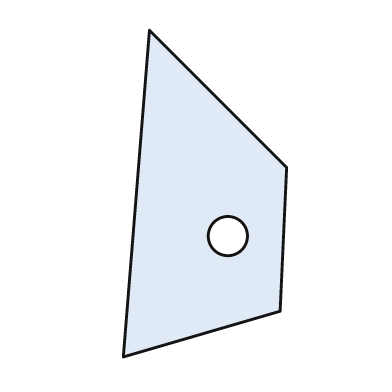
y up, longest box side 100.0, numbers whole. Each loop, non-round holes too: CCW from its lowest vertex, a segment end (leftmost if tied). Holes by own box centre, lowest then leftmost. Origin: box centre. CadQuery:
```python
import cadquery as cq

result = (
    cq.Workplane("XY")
    .moveTo(-25.0, -50.0)
    .lineTo(23.0, -36.0)
    .lineTo(25.0, 8.0)
    .lineTo(-17.0, 50.0)
    .close()
    .moveTo(7.0, -13.0)
    .circle(6.0)
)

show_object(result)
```